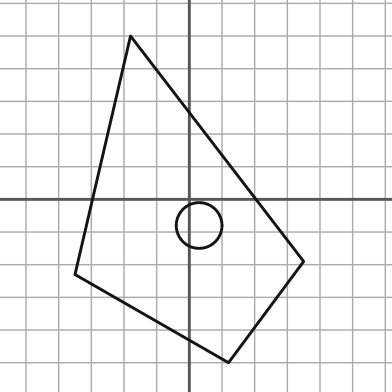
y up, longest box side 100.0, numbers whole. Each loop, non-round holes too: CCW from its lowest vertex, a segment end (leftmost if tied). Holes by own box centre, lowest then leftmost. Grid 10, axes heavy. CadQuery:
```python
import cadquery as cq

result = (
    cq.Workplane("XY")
    .moveTo(12.0, -50.0)
    .lineTo(35.0, -19.0)
    .lineTo(-18.0, 50.0)
    .lineTo(-35.0, -23.0)
    .close()
    .moveTo(3.0, -8.0)
    .circle(7.0)
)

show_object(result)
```